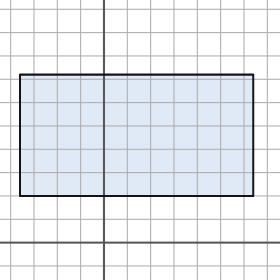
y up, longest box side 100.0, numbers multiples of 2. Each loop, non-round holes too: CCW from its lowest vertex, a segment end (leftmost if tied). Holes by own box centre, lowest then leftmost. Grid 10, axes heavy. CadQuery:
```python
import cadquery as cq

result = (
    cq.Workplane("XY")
    .moveTo(-36.0, 20.0)
    .lineTo(64.0, 20.0)
    .lineTo(64.0, 72.0)
    .lineTo(-36.0, 72.0)
    .close()
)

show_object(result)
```